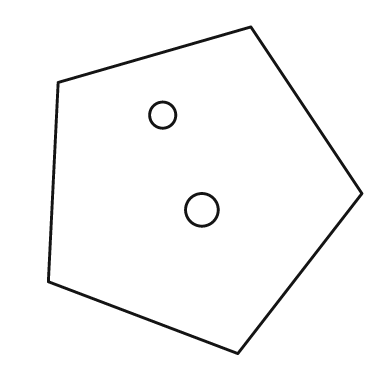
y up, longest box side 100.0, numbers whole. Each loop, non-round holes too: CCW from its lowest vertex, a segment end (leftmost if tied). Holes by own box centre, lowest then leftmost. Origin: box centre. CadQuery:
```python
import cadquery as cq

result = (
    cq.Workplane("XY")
    .moveTo(10.0, -50.0)
    .lineTo(48.0, -1.0)
    .lineTo(14.0, 50.0)
    .lineTo(-45.0, 33.0)
    .lineTo(-48.0, -28.0)
    .close()
    .moveTo(-1.0, -6.0)
    .circle(5.0)
    .moveTo(-13.0, 23.0)
    .circle(4.0)
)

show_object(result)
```